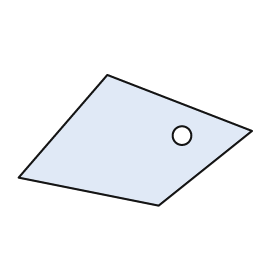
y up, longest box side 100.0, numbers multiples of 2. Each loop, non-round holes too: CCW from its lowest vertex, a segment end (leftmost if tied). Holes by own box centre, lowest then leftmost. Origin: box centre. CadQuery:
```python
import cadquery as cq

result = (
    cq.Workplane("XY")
    .moveTo(10.0, -28.0)
    .lineTo(50.0, 4.0)
    .lineTo(-12.0, 28.0)
    .lineTo(-50.0, -16.0)
    .close()
    .moveTo(20.0, 2.0)
    .circle(4.0)
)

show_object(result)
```